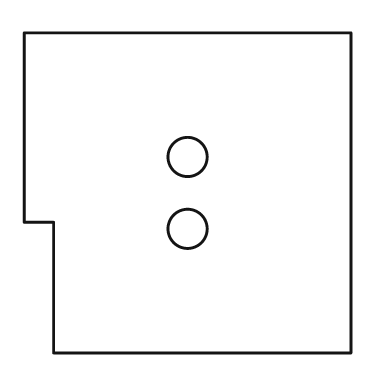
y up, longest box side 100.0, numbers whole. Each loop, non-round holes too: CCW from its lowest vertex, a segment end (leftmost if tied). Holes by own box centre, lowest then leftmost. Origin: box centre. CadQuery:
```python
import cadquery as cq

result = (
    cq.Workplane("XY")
    .moveTo(-41.0, -49.0)
    .lineTo(50.0, -49.0)
    .lineTo(50.0, 49.0)
    .lineTo(-50.0, 49.0)
    .lineTo(-50.0, -9.0)
    .lineTo(-41.0, -9.0)
    .close()
    .moveTo(0.0, -11.0)
    .circle(6.0)
    .moveTo(0.0, 11.0)
    .circle(6.0)
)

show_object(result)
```